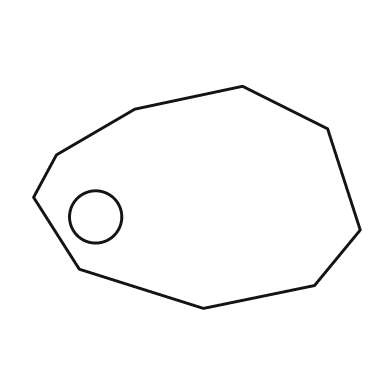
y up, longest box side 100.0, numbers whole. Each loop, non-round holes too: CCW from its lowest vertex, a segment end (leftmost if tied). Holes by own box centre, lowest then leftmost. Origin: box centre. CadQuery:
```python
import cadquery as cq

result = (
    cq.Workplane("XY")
    .moveTo(2.0, -34.0)
    .lineTo(36.0, -27.0)
    .lineTo(50.0, -10.0)
    .lineTo(40.0, 21.0)
    .lineTo(14.0, 34.0)
    .lineTo(-19.0, 27.0)
    .lineTo(-43.0, 13.0)
    .lineTo(-50.0, 0.0)
    .lineTo(-36.0, -22.0)
    .close()
    .moveTo(-31.0, -6.0)
    .circle(8.0)
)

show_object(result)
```